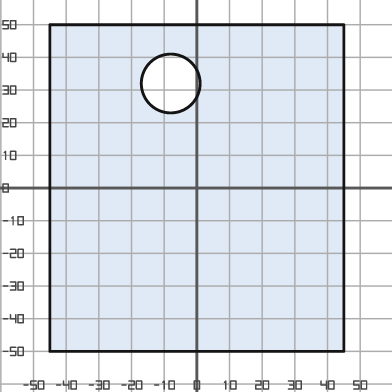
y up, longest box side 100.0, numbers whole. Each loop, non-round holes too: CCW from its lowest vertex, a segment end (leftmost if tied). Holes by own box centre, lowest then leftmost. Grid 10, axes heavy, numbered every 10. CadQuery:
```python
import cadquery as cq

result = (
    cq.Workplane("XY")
    .moveTo(-45.0, -50.0)
    .lineTo(45.0, -50.0)
    .lineTo(45.0, 50.0)
    .lineTo(-45.0, 50.0)
    .close()
    .moveTo(-8.0, 32.0)
    .circle(9.0)
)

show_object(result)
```